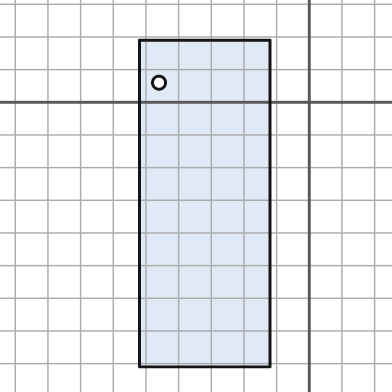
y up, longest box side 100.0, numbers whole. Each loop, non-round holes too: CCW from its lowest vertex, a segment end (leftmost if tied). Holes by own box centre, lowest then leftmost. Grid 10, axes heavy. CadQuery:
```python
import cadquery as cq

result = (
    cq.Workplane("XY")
    .moveTo(-52.0, -81.0)
    .lineTo(-12.0, -81.0)
    .lineTo(-12.0, 19.0)
    .lineTo(-52.0, 19.0)
    .close()
    .moveTo(-46.0, 6.0)
    .circle(2.0)
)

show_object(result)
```